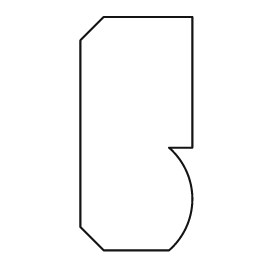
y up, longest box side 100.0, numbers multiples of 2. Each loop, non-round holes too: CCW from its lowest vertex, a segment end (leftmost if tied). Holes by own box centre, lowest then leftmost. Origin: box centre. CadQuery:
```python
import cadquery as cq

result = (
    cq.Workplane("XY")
    .moveTo(-14.0, -50.0)
    .lineTo(14.0, -50.0)
    .threePointArc((24.0, -28.0), (14.0, -6.0))
    .lineTo(24.0, -6.0)
    .lineTo(24.0, 50.0)
    .lineTo(-14.0, 50.0)
    .lineTo(-24.0, 40.0)
    .lineTo(-24.0, -40.0)
    .close()
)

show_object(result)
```